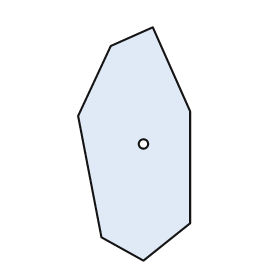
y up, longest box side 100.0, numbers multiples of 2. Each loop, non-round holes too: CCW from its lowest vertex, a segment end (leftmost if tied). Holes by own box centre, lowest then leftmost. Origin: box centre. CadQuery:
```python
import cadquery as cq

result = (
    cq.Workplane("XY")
    .moveTo(4.0, -50.0)
    .lineTo(24.0, -34.0)
    .lineTo(24.0, 14.0)
    .lineTo(8.0, 50.0)
    .lineTo(-10.0, 42.0)
    .lineTo(-24.0, 12.0)
    .lineTo(-14.0, -40.0)
    .close()
    .moveTo(4.0, 0.0)
    .circle(2.0)
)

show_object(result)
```